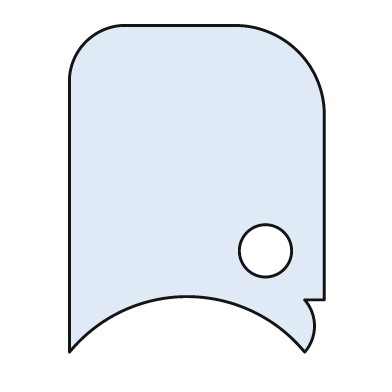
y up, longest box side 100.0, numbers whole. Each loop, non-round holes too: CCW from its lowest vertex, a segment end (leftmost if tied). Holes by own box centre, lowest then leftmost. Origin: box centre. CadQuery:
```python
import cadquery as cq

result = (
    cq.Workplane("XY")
    .moveTo(-39.0, -50.0)
    .threePointArc((-3.0, -33.0), (33.0, -50.0))
    .threePointArc((36.0, -42.0), (33.0, -34.0))
    .lineTo(39.0, -34.0)
    .lineTo(39.0, 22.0)
    .threePointArc((31.0, 42.0), (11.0, 50.0))
    .lineTo(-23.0, 50.0)
    .threePointArc((-34.0, 45.0), (-39.0, 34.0))
    .close()
    .moveTo(21.0, -19.0)
    .circle(8.0)
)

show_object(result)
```